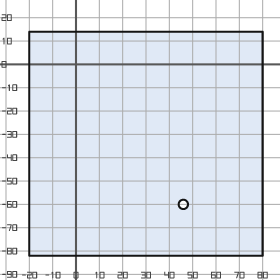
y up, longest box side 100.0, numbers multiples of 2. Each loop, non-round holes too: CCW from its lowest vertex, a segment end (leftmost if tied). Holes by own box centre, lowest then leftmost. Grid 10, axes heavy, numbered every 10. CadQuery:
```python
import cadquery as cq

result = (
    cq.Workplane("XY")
    .moveTo(-20.0, -82.0)
    .lineTo(80.0, -82.0)
    .lineTo(80.0, 14.0)
    .lineTo(-20.0, 14.0)
    .close()
    .moveTo(46.0, -60.0)
    .circle(2.0)
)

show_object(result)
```